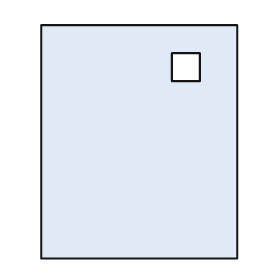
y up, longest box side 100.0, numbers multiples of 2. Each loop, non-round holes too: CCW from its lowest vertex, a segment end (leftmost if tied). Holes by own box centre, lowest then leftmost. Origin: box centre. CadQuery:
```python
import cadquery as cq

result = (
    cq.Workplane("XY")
    .moveTo(-42.0, -50.0)
    .lineTo(42.0, -50.0)
    .lineTo(42.0, 50.0)
    .lineTo(-42.0, 50.0)
    .close()
    .moveTo(14.0, 26.0)
    .lineTo(26.0, 26.0)
    .lineTo(26.0, 38.0)
    .lineTo(14.0, 38.0)
    .close()
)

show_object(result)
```